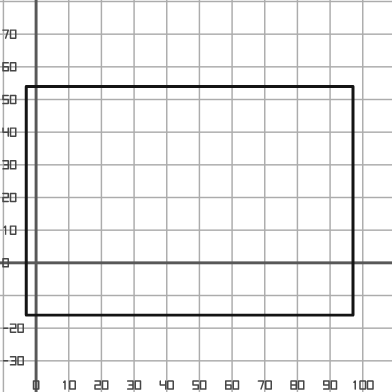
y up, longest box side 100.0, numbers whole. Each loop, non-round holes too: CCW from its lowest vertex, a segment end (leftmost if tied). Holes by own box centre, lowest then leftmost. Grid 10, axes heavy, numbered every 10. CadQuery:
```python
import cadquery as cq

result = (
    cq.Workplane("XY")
    .moveTo(-3.0, -16.0)
    .lineTo(97.0, -16.0)
    .lineTo(97.0, 54.0)
    .lineTo(-3.0, 54.0)
    .close()
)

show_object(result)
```